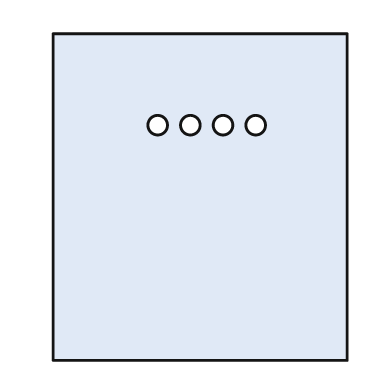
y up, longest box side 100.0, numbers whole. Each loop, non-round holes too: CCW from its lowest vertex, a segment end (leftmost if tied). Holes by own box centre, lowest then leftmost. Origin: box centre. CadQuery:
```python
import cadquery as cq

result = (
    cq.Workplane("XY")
    .moveTo(-45.0, -50.0)
    .lineTo(45.0, -50.0)
    .lineTo(45.0, 50.0)
    .lineTo(-45.0, 50.0)
    .close()
    .moveTo(-13.0, 22.0)
    .circle(3.0)
    .moveTo(-3.0, 22.0)
    .circle(3.0)
    .moveTo(7.0, 22.0)
    .circle(3.0)
    .moveTo(17.0, 22.0)
    .circle(3.0)
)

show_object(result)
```